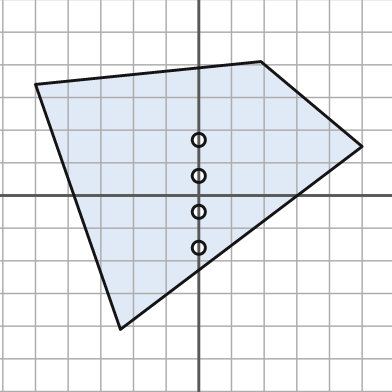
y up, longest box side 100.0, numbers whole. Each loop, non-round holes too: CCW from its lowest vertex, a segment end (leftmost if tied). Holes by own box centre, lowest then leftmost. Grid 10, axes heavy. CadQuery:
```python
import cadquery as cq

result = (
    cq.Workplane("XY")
    .moveTo(-24.0, -41.0)
    .lineTo(50.0, 15.0)
    .lineTo(19.0, 41.0)
    .lineTo(-50.0, 34.0)
    .close()
    .moveTo(0.0, -16.0)
    .circle(2.0)
    .moveTo(0.0, -5.0)
    .circle(2.0)
    .moveTo(0.0, 6.0)
    .circle(2.0)
    .moveTo(0.0, 17.0)
    .circle(2.0)
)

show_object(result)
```